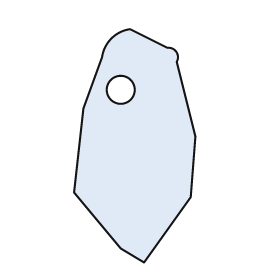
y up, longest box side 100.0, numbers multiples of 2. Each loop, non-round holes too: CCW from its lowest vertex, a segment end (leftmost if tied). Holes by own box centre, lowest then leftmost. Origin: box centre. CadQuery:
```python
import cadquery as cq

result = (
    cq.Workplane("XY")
    .moveTo(4.0, -50.0)
    .lineTo(24.0, -22.0)
    .lineTo(26.0, 4.0)
    .lineTo(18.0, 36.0)
    .threePointArc((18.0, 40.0), (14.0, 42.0))
    .lineTo(-2.0, 50.0)
    .threePointArc((-10.0, 46.0), (-14.0, 38.0))
    .lineTo(-22.0, 16.0)
    .lineTo(-26.0, -20.0)
    .lineTo(-6.0, -44.0)
    .close()
    .moveTo(-6.0, 24.0)
    .circle(6.0)
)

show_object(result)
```